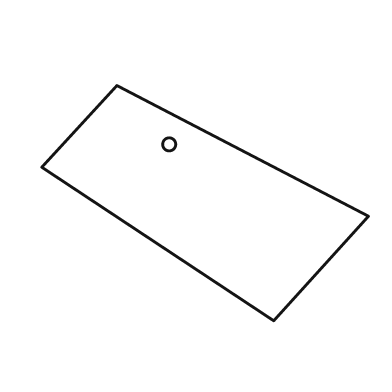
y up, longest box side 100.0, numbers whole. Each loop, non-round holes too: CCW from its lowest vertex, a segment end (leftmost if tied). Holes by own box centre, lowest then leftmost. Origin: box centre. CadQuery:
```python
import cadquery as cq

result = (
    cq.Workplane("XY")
    .moveTo(21.0, -36.0)
    .lineTo(50.0, -4.0)
    .lineTo(-27.0, 36.0)
    .lineTo(-50.0, 11.0)
    .close()
    .moveTo(-11.0, 18.0)
    .circle(2.0)
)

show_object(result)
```